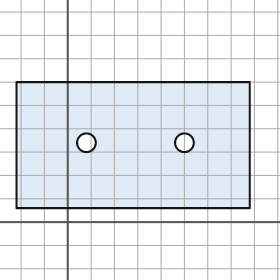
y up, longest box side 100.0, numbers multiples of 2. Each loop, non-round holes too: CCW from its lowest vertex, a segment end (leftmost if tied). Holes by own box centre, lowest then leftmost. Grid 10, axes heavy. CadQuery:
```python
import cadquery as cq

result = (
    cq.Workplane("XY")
    .moveTo(-22.0, 6.0)
    .lineTo(78.0, 6.0)
    .lineTo(78.0, 60.0)
    .lineTo(-22.0, 60.0)
    .close()
    .moveTo(8.0, 34.0)
    .circle(4.0)
    .moveTo(50.0, 34.0)
    .circle(4.0)
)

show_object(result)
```